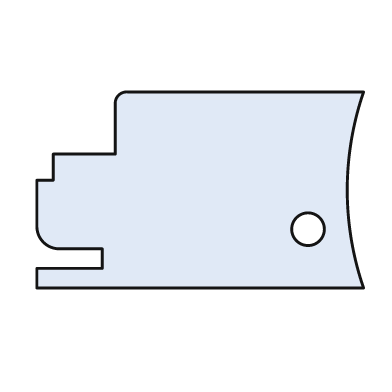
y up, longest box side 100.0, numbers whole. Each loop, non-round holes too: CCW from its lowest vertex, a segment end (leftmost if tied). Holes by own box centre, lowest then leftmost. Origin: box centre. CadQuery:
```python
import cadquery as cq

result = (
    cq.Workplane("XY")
    .moveTo(-50.0, -30.0)
    .lineTo(50.0, -30.0)
    .threePointArc((45.0, 0.0), (50.0, 30.0))
    .lineTo(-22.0, 30.0)
    .threePointArc((-25.0, 29.0), (-26.0, 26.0))
    .lineTo(-26.0, 11.0)
    .lineTo(-45.0, 11.0)
    .lineTo(-45.0, 3.0)
    .lineTo(-50.0, 3.0)
    .lineTo(-50.0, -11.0)
    .threePointArc((-48.0, -16.0), (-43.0, -18.0))
    .lineTo(-30.0, -18.0)
    .lineTo(-30.0, -24.0)
    .lineTo(-50.0, -24.0)
    .close()
    .moveTo(33.0, -12.0)
    .circle(5.0)
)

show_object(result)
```